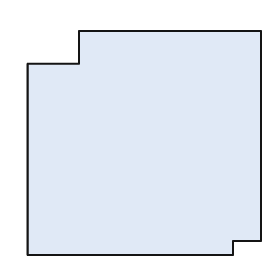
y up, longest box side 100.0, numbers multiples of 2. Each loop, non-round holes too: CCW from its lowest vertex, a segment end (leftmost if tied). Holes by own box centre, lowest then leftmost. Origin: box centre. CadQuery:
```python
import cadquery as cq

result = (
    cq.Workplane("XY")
    .moveTo(-50.0, -48.0)
    .lineTo(38.0, -48.0)
    .lineTo(38.0, -42.0)
    .lineTo(50.0, -42.0)
    .lineTo(50.0, 48.0)
    .lineTo(-28.0, 48.0)
    .lineTo(-28.0, 34.0)
    .lineTo(-50.0, 34.0)
    .close()
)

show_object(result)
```